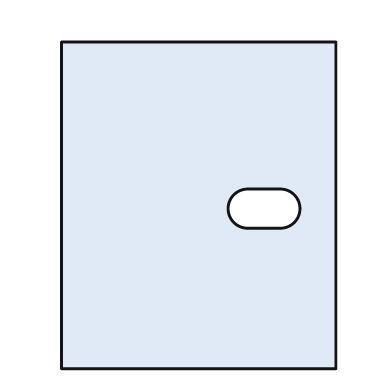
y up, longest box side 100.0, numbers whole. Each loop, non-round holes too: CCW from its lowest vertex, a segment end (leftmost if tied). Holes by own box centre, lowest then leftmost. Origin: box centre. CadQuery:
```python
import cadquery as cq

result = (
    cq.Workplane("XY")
    .moveTo(-42.0, -50.0)
    .lineTo(42.0, -50.0)
    .lineTo(42.0, 50.0)
    .lineTo(-42.0, 50.0)
    .close()
    .moveTo(15.0, -7.0)
    .lineTo(25.0, -7.0)
    .threePointArc((31.0, -1.0), (25.0, 5.0))
    .lineTo(15.0, 5.0)
    .threePointArc((9.0, -1.0), (15.0, -7.0))
    .close()
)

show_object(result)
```